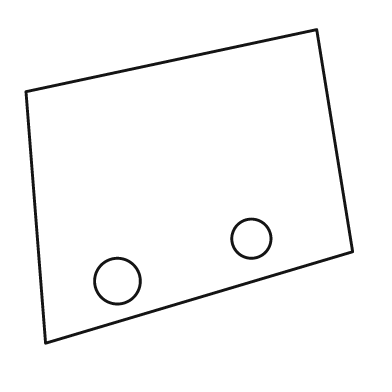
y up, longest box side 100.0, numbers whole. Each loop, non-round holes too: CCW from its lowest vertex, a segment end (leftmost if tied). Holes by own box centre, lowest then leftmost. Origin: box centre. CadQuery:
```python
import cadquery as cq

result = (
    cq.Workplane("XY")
    .moveTo(-44.0, -48.0)
    .lineTo(50.0, -20.0)
    .lineTo(39.0, 48.0)
    .lineTo(-50.0, 29.0)
    .close()
    .moveTo(-22.0, -29.0)
    .circle(7.0)
    .moveTo(19.0, -16.0)
    .circle(6.0)
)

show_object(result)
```